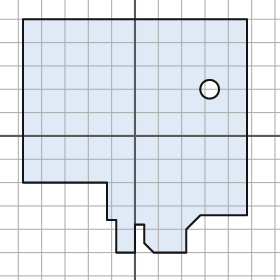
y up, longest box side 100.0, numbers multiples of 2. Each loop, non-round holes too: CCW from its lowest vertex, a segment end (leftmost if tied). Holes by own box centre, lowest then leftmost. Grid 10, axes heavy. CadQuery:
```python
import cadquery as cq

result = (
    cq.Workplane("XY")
    .moveTo(-8.0, -50.0)
    .lineTo(0.0, -50.0)
    .lineTo(0.0, -38.0)
    .lineTo(4.0, -38.0)
    .lineTo(4.0, -46.0)
    .lineTo(8.0, -50.0)
    .lineTo(22.0, -50.0)
    .lineTo(22.0, -40.0)
    .lineTo(28.0, -34.0)
    .lineTo(48.0, -34.0)
    .lineTo(48.0, 50.0)
    .lineTo(-48.0, 50.0)
    .lineTo(-48.0, -20.0)
    .lineTo(-12.0, -20.0)
    .lineTo(-12.0, -36.0)
    .lineTo(-8.0, -36.0)
    .close()
    .moveTo(32.0, 20.0)
    .circle(4.0)
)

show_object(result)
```